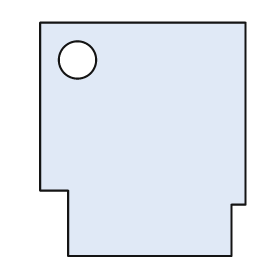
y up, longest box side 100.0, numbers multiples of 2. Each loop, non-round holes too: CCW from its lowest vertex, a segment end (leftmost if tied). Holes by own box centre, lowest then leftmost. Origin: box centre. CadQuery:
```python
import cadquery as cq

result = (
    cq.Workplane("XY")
    .moveTo(-32.0, -50.0)
    .lineTo(38.0, -50.0)
    .lineTo(38.0, -28.0)
    .lineTo(44.0, -28.0)
    .lineTo(44.0, 50.0)
    .lineTo(-44.0, 50.0)
    .lineTo(-44.0, -22.0)
    .lineTo(-32.0, -22.0)
    .close()
    .moveTo(-28.0, 34.0)
    .circle(8.0)
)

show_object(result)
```